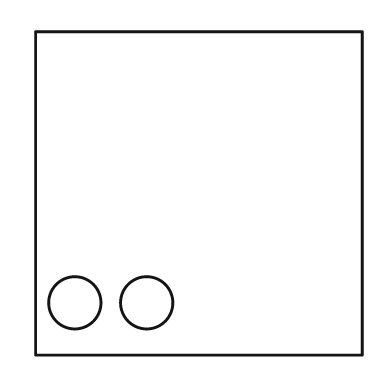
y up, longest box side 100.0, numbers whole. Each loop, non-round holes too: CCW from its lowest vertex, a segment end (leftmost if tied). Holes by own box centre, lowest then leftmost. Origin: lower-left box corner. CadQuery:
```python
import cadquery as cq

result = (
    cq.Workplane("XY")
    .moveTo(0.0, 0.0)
    .lineTo(100.0, 0.0)
    .lineTo(100.0, 99.0)
    .lineTo(0.0, 99.0)
    .close()
    .moveTo(12.0, 16.0)
    .circle(8.0)
    .moveTo(34.0, 16.0)
    .circle(8.0)
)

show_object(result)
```